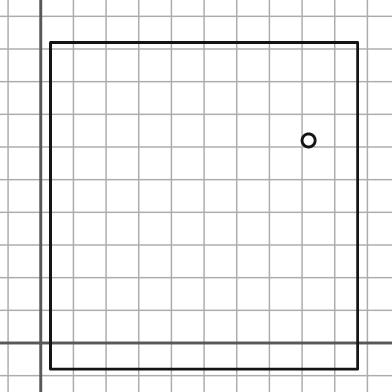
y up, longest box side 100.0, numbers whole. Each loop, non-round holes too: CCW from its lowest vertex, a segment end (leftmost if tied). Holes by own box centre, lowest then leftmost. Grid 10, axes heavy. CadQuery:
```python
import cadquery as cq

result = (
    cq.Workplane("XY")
    .moveTo(3.0, -8.0)
    .lineTo(97.0, -8.0)
    .lineTo(97.0, 92.0)
    .lineTo(3.0, 92.0)
    .close()
    .moveTo(82.0, 62.0)
    .circle(2.0)
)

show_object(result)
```